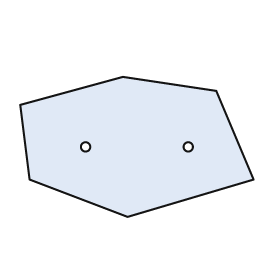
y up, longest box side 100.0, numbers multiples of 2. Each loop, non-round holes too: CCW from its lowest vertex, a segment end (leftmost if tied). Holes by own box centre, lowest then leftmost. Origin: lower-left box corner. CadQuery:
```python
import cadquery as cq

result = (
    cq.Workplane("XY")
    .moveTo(46.0, 0.0)
    .lineTo(100.0, 16.0)
    .lineTo(84.0, 54.0)
    .lineTo(44.0, 60.0)
    .lineTo(0.0, 48.0)
    .lineTo(4.0, 16.0)
    .close()
    .moveTo(28.0, 30.0)
    .circle(2.0)
    .moveTo(72.0, 30.0)
    .circle(2.0)
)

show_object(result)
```